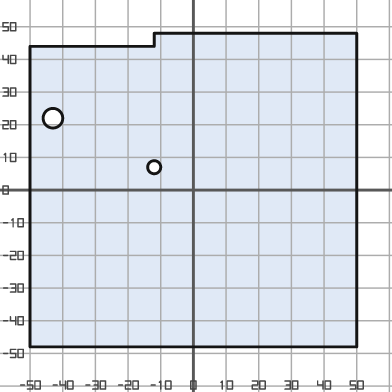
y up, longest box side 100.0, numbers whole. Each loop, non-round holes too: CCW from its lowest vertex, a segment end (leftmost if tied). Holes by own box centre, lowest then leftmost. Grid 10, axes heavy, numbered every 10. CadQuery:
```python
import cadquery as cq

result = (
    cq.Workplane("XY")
    .moveTo(-50.0, -48.0)
    .lineTo(50.0, -48.0)
    .lineTo(50.0, 48.0)
    .lineTo(-12.0, 48.0)
    .lineTo(-12.0, 44.0)
    .lineTo(-50.0, 44.0)
    .close()
    .moveTo(-12.0, 7.0)
    .circle(2.0)
    .moveTo(-43.0, 22.0)
    .circle(3.0)
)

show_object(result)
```